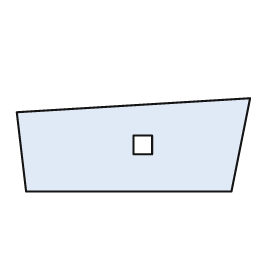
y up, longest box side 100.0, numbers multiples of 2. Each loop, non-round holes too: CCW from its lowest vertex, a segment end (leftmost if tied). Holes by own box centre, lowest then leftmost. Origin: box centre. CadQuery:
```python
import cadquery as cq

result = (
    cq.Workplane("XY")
    .moveTo(-46.0, -20.0)
    .lineTo(42.0, -20.0)
    .lineTo(50.0, 20.0)
    .lineTo(-50.0, 14.0)
    .close()
    .moveTo(0.0, -4.0)
    .lineTo(8.0, -4.0)
    .lineTo(8.0, 4.0)
    .lineTo(0.0, 4.0)
    .close()
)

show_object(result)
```